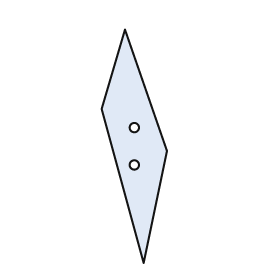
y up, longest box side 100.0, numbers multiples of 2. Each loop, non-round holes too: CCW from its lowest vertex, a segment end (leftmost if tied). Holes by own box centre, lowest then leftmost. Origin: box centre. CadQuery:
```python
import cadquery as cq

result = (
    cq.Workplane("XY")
    .moveTo(4.0, -50.0)
    .lineTo(14.0, -2.0)
    .lineTo(-4.0, 50.0)
    .lineTo(-14.0, 16.0)
    .close()
    .moveTo(0.0, -8.0)
    .circle(2.0)
    .moveTo(0.0, 8.0)
    .circle(2.0)
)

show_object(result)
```